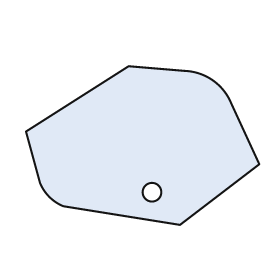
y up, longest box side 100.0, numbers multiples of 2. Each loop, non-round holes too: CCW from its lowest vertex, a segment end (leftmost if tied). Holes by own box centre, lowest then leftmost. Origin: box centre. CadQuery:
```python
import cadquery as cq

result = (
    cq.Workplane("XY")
    .moveTo(16.0, -34.0)
    .lineTo(50.0, -8.0)
    .lineTo(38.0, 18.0)
    .threePointArc((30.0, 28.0), (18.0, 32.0))
    .lineTo(-6.0, 34.0)
    .lineTo(-50.0, 6.0)
    .lineTo(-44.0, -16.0)
    .threePointArc((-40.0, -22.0), (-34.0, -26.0))
    .close()
    .moveTo(4.0, -20.0)
    .circle(4.0)
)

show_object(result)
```